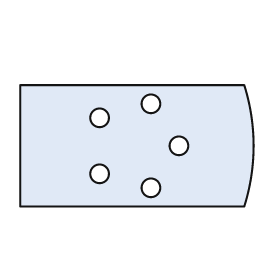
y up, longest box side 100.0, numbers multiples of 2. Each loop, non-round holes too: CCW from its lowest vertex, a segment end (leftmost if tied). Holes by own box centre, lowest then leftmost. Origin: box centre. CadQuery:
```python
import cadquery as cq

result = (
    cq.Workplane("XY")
    .moveTo(-50.0, -26.0)
    .lineTo(46.0, -26.0)
    .threePointArc((50.0, 0.0), (46.0, 26.0))
    .lineTo(-50.0, 26.0)
    .close()
    .moveTo(6.0, -18.0)
    .circle(4.0)
    .moveTo(-16.0, -12.0)
    .circle(4.0)
    .moveTo(18.0, 0.0)
    .circle(4.0)
    .moveTo(-16.0, 12.0)
    .circle(4.0)
    .moveTo(6.0, 18.0)
    .circle(4.0)
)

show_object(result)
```